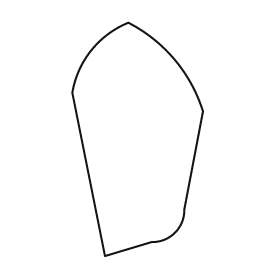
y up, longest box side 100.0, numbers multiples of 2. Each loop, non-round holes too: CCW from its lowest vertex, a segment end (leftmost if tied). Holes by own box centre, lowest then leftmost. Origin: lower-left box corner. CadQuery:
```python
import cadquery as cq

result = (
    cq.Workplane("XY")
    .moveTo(14.0, 0.0)
    .lineTo(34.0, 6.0)
    .threePointArc((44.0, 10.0), (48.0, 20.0))
    .lineTo(56.0, 62.0)
    .threePointArc((44.0, 84.0), (24.0, 100.0))
    .threePointArc((8.0, 88.0), (0.0, 70.0))
    .close()
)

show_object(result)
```